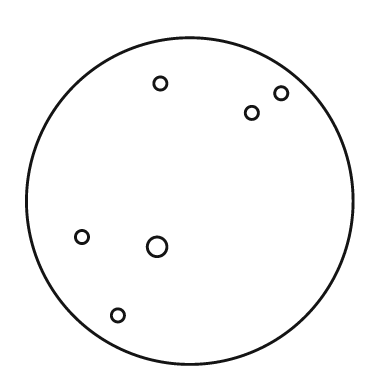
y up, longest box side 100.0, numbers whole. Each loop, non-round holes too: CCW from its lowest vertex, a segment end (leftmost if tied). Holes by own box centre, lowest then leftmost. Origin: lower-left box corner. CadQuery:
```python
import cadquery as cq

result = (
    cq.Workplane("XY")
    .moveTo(50.0, 50.0)
    .circle(50.0)
    .moveTo(28.0, 15.0)
    .circle(2.0)
    .moveTo(40.0, 36.0)
    .circle(3.0)
    .moveTo(17.0, 39.0)
    .circle(2.0)
    .moveTo(69.0, 77.0)
    .circle(2.0)
    .moveTo(78.0, 83.0)
    .circle(2.0)
    .moveTo(41.0, 86.0)
    .circle(2.0)
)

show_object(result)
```